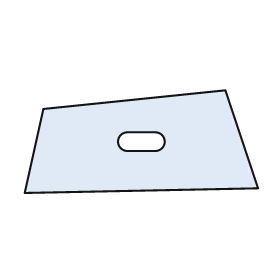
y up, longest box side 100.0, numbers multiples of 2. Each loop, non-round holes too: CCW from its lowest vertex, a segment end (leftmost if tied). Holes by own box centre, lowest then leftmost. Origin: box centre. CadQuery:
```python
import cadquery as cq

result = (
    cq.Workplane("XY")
    .moveTo(-50.0, -22.0)
    .lineTo(50.0, -20.0)
    .lineTo(36.0, 22.0)
    .lineTo(-42.0, 14.0)
    .close()
    .moveTo(-6.0, -4.0)
    .lineTo(6.0, -4.0)
    .threePointArc((10.0, 0.0), (6.0, 4.0))
    .lineTo(-6.0, 4.0)
    .threePointArc((-10.0, 0.0), (-6.0, -4.0))
    .close()
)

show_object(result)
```